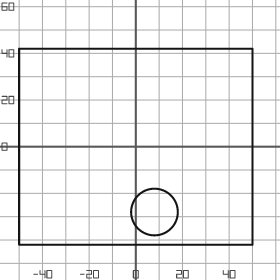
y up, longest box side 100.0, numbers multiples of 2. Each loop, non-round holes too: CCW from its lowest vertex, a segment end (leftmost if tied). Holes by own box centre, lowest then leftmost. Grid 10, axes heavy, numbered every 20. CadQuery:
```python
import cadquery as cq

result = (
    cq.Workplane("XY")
    .moveTo(-50.0, -42.0)
    .lineTo(50.0, -42.0)
    .lineTo(50.0, 42.0)
    .lineTo(-50.0, 42.0)
    .close()
    .moveTo(8.0, -28.0)
    .circle(10.0)
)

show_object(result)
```